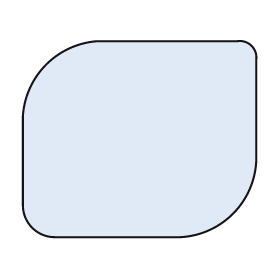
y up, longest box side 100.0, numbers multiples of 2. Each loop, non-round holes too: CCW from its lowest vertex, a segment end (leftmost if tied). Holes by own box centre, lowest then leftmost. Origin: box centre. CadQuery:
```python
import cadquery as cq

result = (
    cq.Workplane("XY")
    .moveTo(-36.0, -42.0)
    .lineTo(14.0, -42.0)
    .threePointArc((40.0, -32.0), (50.0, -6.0))
    .lineTo(50.0, 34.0)
    .threePointArc((48.0, 40.0), (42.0, 42.0))
    .lineTo(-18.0, 42.0)
    .threePointArc((-40.0, 32.0), (-50.0, 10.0))
    .lineTo(-50.0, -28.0)
    .threePointArc((-46.0, -38.0), (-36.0, -42.0))
    .close()
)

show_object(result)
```